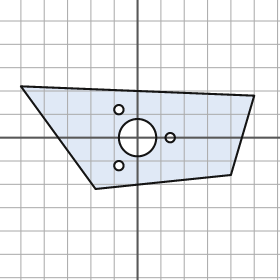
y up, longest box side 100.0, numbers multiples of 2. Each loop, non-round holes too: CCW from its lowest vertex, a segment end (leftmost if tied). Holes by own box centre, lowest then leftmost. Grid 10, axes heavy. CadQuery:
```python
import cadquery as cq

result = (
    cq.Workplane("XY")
    .moveTo(-18.0, -22.0)
    .lineTo(40.0, -16.0)
    .lineTo(50.0, 18.0)
    .lineTo(-50.0, 22.0)
    .close()
    .moveTo(-8.0, -12.0)
    .circle(2.0)
    .moveTo(0.0, 0.0)
    .circle(8.0)
    .moveTo(14.0, 0.0)
    .circle(2.0)
    .moveTo(-8.0, 12.0)
    .circle(2.0)
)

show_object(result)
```